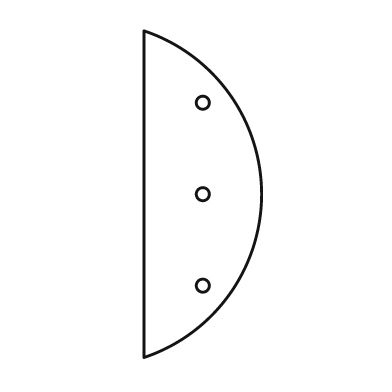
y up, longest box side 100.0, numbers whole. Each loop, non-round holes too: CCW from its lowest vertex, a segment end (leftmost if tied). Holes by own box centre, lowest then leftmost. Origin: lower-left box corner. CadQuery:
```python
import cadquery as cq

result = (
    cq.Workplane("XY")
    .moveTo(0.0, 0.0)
    .threePointArc((36.0, 50.0), (0.0, 100.0))
    .close()
    .moveTo(18.0, 22.0)
    .circle(2.0)
    .moveTo(18.0, 50.0)
    .circle(2.0)
    .moveTo(18.0, 78.0)
    .circle(2.0)
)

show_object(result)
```